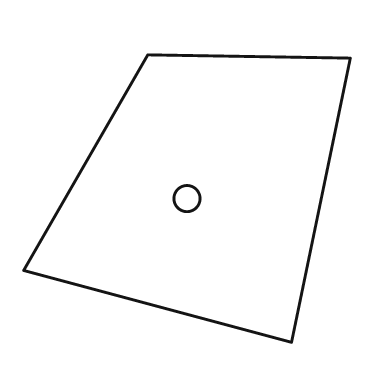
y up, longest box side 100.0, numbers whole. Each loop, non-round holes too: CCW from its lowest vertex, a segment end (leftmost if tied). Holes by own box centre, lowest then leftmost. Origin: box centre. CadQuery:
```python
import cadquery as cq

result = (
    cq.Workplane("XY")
    .moveTo(32.0, -44.0)
    .lineTo(50.0, 43.0)
    .lineTo(-12.0, 44.0)
    .lineTo(-50.0, -22.0)
    .close()
    .moveTo(0.0, 0.0)
    .circle(4.0)
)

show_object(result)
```